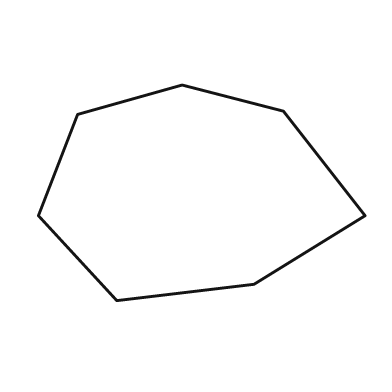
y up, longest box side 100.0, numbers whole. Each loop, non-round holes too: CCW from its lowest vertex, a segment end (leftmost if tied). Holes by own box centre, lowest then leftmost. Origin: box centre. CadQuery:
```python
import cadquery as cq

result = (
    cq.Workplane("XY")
    .moveTo(-26.0, -33.0)
    .lineTo(16.0, -28.0)
    .lineTo(50.0, -7.0)
    .lineTo(25.0, 25.0)
    .lineTo(-6.0, 33.0)
    .lineTo(-38.0, 24.0)
    .lineTo(-50.0, -7.0)
    .close()
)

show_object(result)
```